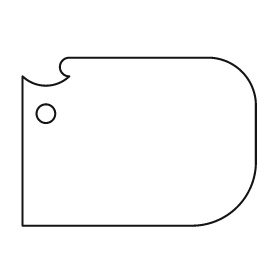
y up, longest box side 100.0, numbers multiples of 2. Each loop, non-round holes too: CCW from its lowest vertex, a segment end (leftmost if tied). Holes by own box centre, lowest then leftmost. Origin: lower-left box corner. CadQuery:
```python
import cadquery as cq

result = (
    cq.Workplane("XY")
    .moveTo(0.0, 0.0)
    .lineTo(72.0, 0.0)
    .threePointArc((92.0, 8.0), (100.0, 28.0))
    .lineTo(100.0, 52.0)
    .threePointArc((94.0, 66.0), (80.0, 72.0))
    .lineTo(20.0, 72.0)
    .threePointArc((16.0, 68.0), (20.0, 64.0))
    .threePointArc((10.0, 60.0), (0.0, 64.0))
    .close()
    .moveTo(10.0, 48.0)
    .circle(4.0)
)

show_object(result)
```